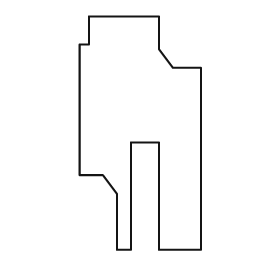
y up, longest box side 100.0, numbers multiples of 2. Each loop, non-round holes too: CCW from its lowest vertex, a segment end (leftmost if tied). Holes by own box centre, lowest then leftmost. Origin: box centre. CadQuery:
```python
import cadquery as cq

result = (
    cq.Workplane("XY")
    .moveTo(-10.0, -50.0)
    .lineTo(-4.0, -50.0)
    .lineTo(-4.0, -4.0)
    .lineTo(8.0, -4.0)
    .lineTo(8.0, -50.0)
    .lineTo(26.0, -50.0)
    .lineTo(26.0, 28.0)
    .lineTo(14.0, 28.0)
    .lineTo(8.0, 36.0)
    .lineTo(8.0, 50.0)
    .lineTo(-22.0, 50.0)
    .lineTo(-22.0, 38.0)
    .lineTo(-26.0, 38.0)
    .lineTo(-26.0, -18.0)
    .lineTo(-16.0, -18.0)
    .lineTo(-10.0, -26.0)
    .close()
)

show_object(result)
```